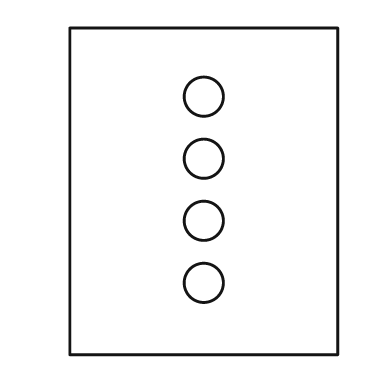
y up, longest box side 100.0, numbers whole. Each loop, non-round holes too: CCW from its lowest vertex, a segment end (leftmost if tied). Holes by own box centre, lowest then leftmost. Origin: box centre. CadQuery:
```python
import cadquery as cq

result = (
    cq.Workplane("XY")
    .moveTo(-41.0, -50.0)
    .lineTo(41.0, -50.0)
    .lineTo(41.0, 50.0)
    .lineTo(-41.0, 50.0)
    .close()
    .moveTo(0.0, -28.0)
    .circle(6.0)
    .moveTo(0.0, -9.0)
    .circle(6.0)
    .moveTo(0.0, 10.0)
    .circle(6.0)
    .moveTo(0.0, 29.0)
    .circle(6.0)
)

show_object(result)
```